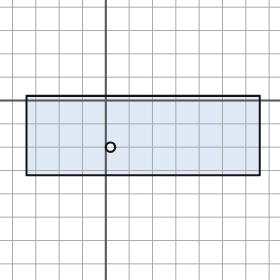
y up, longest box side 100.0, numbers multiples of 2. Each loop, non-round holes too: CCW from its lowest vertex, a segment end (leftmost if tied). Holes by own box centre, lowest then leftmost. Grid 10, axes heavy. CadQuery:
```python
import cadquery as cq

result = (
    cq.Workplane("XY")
    .moveTo(-34.0, -32.0)
    .lineTo(66.0, -32.0)
    .lineTo(66.0, 2.0)
    .lineTo(-34.0, 2.0)
    .close()
    .moveTo(2.0, -20.0)
    .circle(2.0)
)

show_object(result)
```